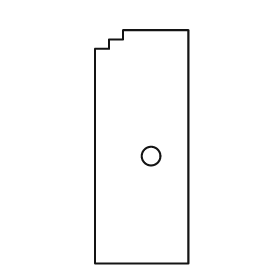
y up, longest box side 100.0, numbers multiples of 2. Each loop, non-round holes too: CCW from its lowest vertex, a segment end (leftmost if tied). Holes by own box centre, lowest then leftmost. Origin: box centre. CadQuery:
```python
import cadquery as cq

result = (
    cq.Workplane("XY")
    .moveTo(-20.0, -50.0)
    .lineTo(20.0, -50.0)
    .lineTo(20.0, 50.0)
    .lineTo(-8.0, 50.0)
    .lineTo(-8.0, 46.0)
    .lineTo(-14.0, 46.0)
    .lineTo(-14.0, 42.0)
    .lineTo(-20.0, 42.0)
    .close()
    .moveTo(4.0, -4.0)
    .circle(4.0)
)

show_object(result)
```